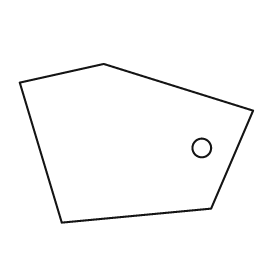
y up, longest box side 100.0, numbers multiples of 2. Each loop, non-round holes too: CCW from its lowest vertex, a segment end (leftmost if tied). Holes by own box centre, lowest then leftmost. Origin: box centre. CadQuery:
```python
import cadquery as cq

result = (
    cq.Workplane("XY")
    .moveTo(-32.0, -34.0)
    .lineTo(32.0, -28.0)
    .lineTo(50.0, 14.0)
    .lineTo(-14.0, 34.0)
    .lineTo(-50.0, 26.0)
    .close()
    .moveTo(28.0, -2.0)
    .circle(4.0)
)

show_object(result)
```